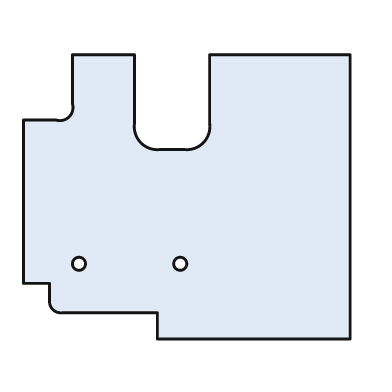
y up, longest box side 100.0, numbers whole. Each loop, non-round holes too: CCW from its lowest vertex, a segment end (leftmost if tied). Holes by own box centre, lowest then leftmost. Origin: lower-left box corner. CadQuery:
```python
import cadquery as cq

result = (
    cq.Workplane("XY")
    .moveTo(41.0, 0.0)
    .lineTo(100.0, 0.0)
    .lineTo(100.0, 87.0)
    .lineTo(57.0, 87.0)
    .lineTo(57.0, 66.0)
    .threePointArc((55.0, 60.0), (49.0, 58.0))
    .lineTo(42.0, 58.0)
    .threePointArc((36.0, 60.0), (34.0, 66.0))
    .lineTo(34.0, 87.0)
    .lineTo(15.0, 87.0)
    .lineTo(15.0, 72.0)
    .threePointArc((14.0, 68.0), (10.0, 67.0))
    .lineTo(0.0, 67.0)
    .lineTo(0.0, 17.0)
    .lineTo(8.0, 17.0)
    .lineTo(8.0, 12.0)
    .threePointArc((9.0, 9.0), (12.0, 8.0))
    .lineTo(41.0, 8.0)
    .close()
    .moveTo(17.0, 23.0)
    .circle(2.0)
    .moveTo(48.0, 23.0)
    .circle(2.0)
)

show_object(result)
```